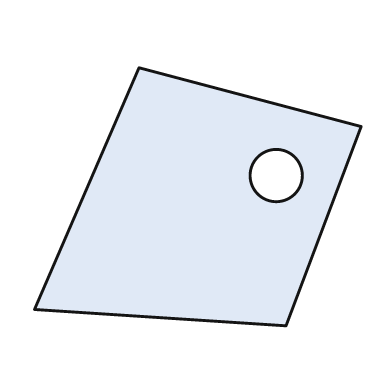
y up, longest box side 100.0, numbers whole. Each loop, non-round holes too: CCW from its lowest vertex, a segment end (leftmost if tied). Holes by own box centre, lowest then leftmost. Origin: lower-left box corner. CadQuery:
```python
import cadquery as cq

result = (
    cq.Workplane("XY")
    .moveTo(77.0, 0.0)
    .lineTo(100.0, 61.0)
    .lineTo(32.0, 79.0)
    .lineTo(0.0, 5.0)
    .close()
    .moveTo(74.0, 46.0)
    .circle(8.0)
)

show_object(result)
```